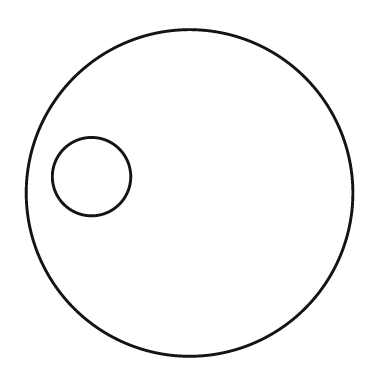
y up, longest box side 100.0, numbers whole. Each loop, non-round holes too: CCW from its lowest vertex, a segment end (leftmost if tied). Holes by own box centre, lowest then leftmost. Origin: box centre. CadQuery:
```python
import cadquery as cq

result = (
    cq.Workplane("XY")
    .moveTo(0.0, 0.0)
    .circle(50.0)
    .moveTo(-30.0, 5.0)
    .circle(12.0)
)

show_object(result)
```